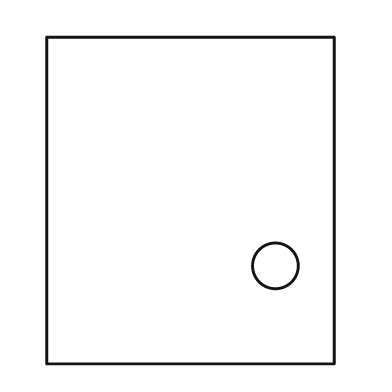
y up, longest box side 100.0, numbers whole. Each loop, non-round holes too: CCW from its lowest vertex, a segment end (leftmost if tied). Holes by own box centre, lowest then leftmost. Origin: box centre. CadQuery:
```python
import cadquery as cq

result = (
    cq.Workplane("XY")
    .moveTo(-44.0, -50.0)
    .lineTo(44.0, -50.0)
    .lineTo(44.0, 50.0)
    .lineTo(-44.0, 50.0)
    .close()
    .moveTo(26.0, -20.0)
    .circle(7.0)
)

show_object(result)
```